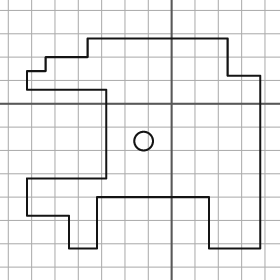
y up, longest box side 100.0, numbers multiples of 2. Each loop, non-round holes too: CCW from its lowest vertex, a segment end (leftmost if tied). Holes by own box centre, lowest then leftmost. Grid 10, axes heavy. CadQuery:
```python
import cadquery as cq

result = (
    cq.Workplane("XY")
    .moveTo(-44.0, -62.0)
    .lineTo(-32.0, -62.0)
    .lineTo(-32.0, -40.0)
    .lineTo(16.0, -40.0)
    .lineTo(16.0, -62.0)
    .lineTo(38.0, -62.0)
    .lineTo(38.0, 12.0)
    .lineTo(24.0, 12.0)
    .lineTo(24.0, 28.0)
    .lineTo(-36.0, 28.0)
    .lineTo(-36.0, 20.0)
    .lineTo(-54.0, 20.0)
    .lineTo(-54.0, 14.0)
    .lineTo(-62.0, 14.0)
    .lineTo(-62.0, 6.0)
    .lineTo(-28.0, 6.0)
    .lineTo(-28.0, -32.0)
    .lineTo(-62.0, -32.0)
    .lineTo(-62.0, -48.0)
    .lineTo(-44.0, -48.0)
    .close()
    .moveTo(-12.0, -16.0)
    .circle(4.0)
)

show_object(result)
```